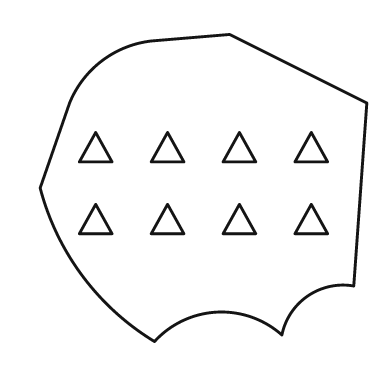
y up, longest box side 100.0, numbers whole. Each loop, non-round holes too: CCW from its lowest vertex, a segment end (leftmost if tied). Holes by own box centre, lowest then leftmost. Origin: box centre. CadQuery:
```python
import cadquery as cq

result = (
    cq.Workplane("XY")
    .moveTo(-15.0, -47.0)
    .threePointArc((4.0, -38.0), (24.0, -45.0))
    .threePointArc((32.0, -33.0), (46.0, -30.0))
    .lineTo(50.0, 26.0)
    .lineTo(8.0, 47.0)
    .lineTo(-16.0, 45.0)
    .threePointArc((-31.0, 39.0), (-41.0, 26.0))
    .lineTo(-50.0, 0.0)
    .threePointArc((-37.0, -27.0), (-15.0, -47.0))
    .close()
    .moveTo(-38.0, -14.0)
    .lineTo(-28.0, -14.0)
    .lineTo(-33.0, -5.0)
    .close()
    .moveTo(-16.0, -14.0)
    .lineTo(-6.0, -14.0)
    .lineTo(-11.0, -5.0)
    .close()
    .moveTo(6.0, -14.0)
    .lineTo(16.0, -14.0)
    .lineTo(11.0, -5.0)
    .close()
    .moveTo(28.0, -14.0)
    .lineTo(38.0, -14.0)
    .lineTo(33.0, -5.0)
    .close()
    .moveTo(-38.0, 8.0)
    .lineTo(-28.0, 8.0)
    .lineTo(-33.0, 17.0)
    .close()
    .moveTo(-16.0, 8.0)
    .lineTo(-6.0, 8.0)
    .lineTo(-11.0, 17.0)
    .close()
    .moveTo(6.0, 8.0)
    .lineTo(16.0, 8.0)
    .lineTo(11.0, 17.0)
    .close()
    .moveTo(28.0, 8.0)
    .lineTo(38.0, 8.0)
    .lineTo(33.0, 17.0)
    .close()
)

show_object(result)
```